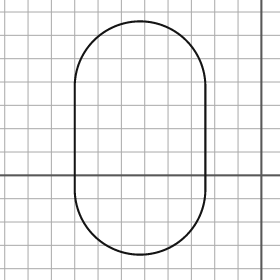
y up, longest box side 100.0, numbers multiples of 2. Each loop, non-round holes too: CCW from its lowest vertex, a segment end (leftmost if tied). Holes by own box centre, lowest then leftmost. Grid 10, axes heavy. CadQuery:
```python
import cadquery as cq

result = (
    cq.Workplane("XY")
    .moveTo(-80.0, -6.0)
    .threePointArc((-52.0, -34.0), (-24.0, -6.0))
    .lineTo(-24.0, 38.0)
    .threePointArc((-52.0, 66.0), (-80.0, 38.0))
    .close()
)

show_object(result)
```